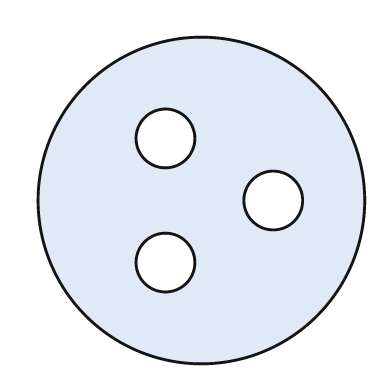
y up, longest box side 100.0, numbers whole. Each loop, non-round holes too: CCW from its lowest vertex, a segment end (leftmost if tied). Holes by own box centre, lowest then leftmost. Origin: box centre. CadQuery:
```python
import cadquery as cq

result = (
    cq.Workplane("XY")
    .moveTo(0.0, 0.0)
    .circle(50.0)
    .moveTo(-11.0, -19.0)
    .circle(9.0)
    .moveTo(22.0, 0.0)
    .circle(9.0)
    .moveTo(-11.0, 19.0)
    .circle(9.0)
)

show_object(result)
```